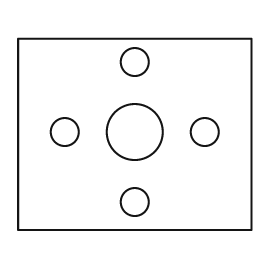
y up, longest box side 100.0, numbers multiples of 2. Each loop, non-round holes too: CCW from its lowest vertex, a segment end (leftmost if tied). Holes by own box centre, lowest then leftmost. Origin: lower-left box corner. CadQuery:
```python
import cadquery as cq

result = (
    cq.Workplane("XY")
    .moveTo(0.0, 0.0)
    .lineTo(100.0, 0.0)
    .lineTo(100.0, 82.0)
    .lineTo(0.0, 82.0)
    .close()
    .moveTo(50.0, 12.0)
    .circle(6.0)
    .moveTo(20.0, 42.0)
    .circle(6.0)
    .moveTo(50.0, 42.0)
    .circle(12.0)
    .moveTo(80.0, 42.0)
    .circle(6.0)
    .moveTo(50.0, 72.0)
    .circle(6.0)
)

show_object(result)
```